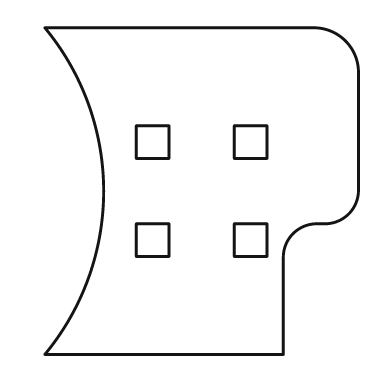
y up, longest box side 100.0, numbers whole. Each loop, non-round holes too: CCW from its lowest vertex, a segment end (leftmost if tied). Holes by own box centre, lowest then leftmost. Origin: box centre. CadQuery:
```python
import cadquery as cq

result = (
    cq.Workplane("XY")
    .moveTo(-48.0, -50.0)
    .lineTo(25.0, -50.0)
    .lineTo(25.0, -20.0)
    .threePointArc((28.0, -13.0), (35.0, -10.0))
    .lineTo(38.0, -10.0)
    .threePointArc((45.0, -7.0), (48.0, 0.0))
    .lineTo(48.0, 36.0)
    .threePointArc((44.0, 46.0), (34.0, 50.0))
    .lineTo(-48.0, 50.0)
    .threePointArc((-30.0, 0.0), (-48.0, -50.0))
    .close()
    .moveTo(-20.0, -20.0)
    .lineTo(-10.0, -20.0)
    .lineTo(-10.0, -10.0)
    .lineTo(-20.0, -10.0)
    .close()
    .moveTo(10.0, -20.0)
    .lineTo(20.0, -20.0)
    .lineTo(20.0, -10.0)
    .lineTo(10.0, -10.0)
    .close()
    .moveTo(-20.0, 10.0)
    .lineTo(-10.0, 10.0)
    .lineTo(-10.0, 20.0)
    .lineTo(-20.0, 20.0)
    .close()
    .moveTo(10.0, 10.0)
    .lineTo(20.0, 10.0)
    .lineTo(20.0, 20.0)
    .lineTo(10.0, 20.0)
    .close()
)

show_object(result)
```